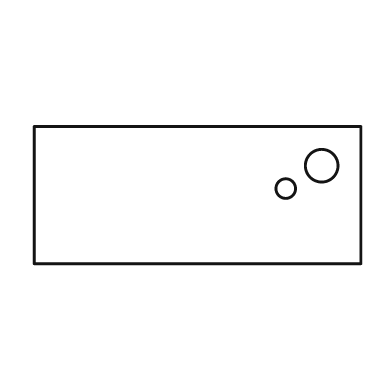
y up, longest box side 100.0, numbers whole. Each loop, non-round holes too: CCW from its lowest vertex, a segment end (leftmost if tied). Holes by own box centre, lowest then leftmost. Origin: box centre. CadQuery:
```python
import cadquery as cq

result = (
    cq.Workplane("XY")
    .moveTo(-50.0, -21.0)
    .lineTo(50.0, -21.0)
    .lineTo(50.0, 21.0)
    .lineTo(-50.0, 21.0)
    .close()
    .moveTo(27.0, 2.0)
    .circle(3.0)
    .moveTo(38.0, 9.0)
    .circle(5.0)
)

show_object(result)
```